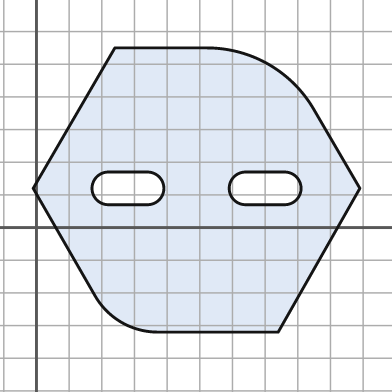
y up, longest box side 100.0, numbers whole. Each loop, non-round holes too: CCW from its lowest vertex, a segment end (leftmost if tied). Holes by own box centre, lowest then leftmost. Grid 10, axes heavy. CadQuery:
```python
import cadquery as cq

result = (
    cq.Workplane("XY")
    .moveTo(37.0, -32.0)
    .lineTo(74.0, -32.0)
    .lineTo(99.0, 12.0)
    .lineTo(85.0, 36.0)
    .threePointArc((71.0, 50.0), (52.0, 55.0))
    .lineTo(24.0, 55.0)
    .lineTo(-1.0, 12.0)
    .lineTo(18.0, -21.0)
    .threePointArc((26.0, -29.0), (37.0, -32.0))
    .close()
    .moveTo(22.0, 7.0)
    .lineTo(34.0, 7.0)
    .threePointArc((39.0, 12.0), (34.0, 17.0))
    .lineTo(22.0, 17.0)
    .threePointArc((17.0, 12.0), (22.0, 7.0))
    .close()
    .moveTo(64.0, 7.0)
    .lineTo(76.0, 7.0)
    .threePointArc((81.0, 12.0), (76.0, 17.0))
    .lineTo(64.0, 17.0)
    .threePointArc((59.0, 12.0), (64.0, 7.0))
    .close()
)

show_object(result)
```